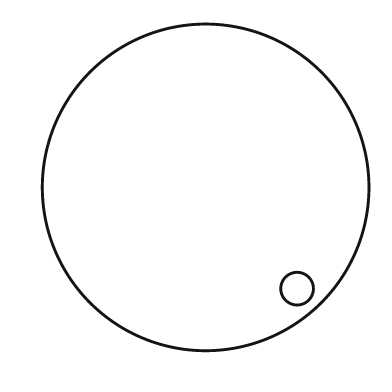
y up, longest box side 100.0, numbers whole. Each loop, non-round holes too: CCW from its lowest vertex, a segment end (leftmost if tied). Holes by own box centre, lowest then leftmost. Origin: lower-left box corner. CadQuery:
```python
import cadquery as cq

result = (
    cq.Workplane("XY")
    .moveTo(50.0, 50.0)
    .circle(50.0)
    .moveTo(78.0, 19.0)
    .circle(5.0)
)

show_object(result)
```